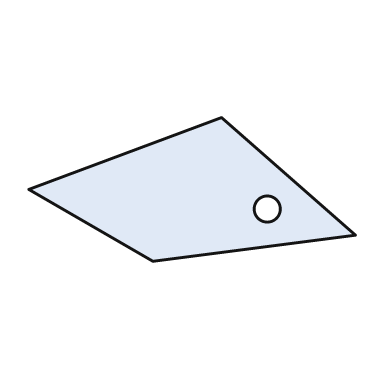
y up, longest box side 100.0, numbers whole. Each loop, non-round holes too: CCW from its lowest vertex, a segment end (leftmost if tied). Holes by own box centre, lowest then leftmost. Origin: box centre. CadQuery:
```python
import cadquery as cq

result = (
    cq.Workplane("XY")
    .moveTo(-12.0, -22.0)
    .lineTo(50.0, -14.0)
    .lineTo(9.0, 22.0)
    .lineTo(-50.0, 0.0)
    .close()
    .moveTo(23.0, -6.0)
    .circle(4.0)
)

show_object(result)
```